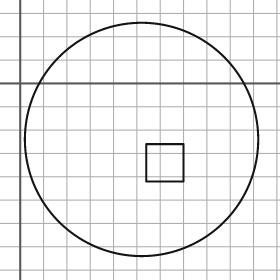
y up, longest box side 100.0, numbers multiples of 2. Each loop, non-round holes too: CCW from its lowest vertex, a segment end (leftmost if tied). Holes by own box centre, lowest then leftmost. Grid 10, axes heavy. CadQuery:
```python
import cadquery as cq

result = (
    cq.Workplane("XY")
    .moveTo(52.0, -24.0)
    .circle(50.0)
    .moveTo(54.0, -42.0)
    .lineTo(70.0, -42.0)
    .lineTo(70.0, -26.0)
    .lineTo(54.0, -26.0)
    .close()
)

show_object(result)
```